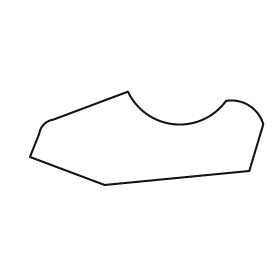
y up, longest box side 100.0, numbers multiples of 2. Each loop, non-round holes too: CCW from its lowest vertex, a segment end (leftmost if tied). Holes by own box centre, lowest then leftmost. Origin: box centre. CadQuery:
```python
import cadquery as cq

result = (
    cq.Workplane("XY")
    .moveTo(-18.0, -20.0)
    .lineTo(44.0, -14.0)
    .lineTo(50.0, 6.0)
    .threePointArc((44.0, 14.0), (34.0, 16.0))
    .threePointArc((12.0, 6.0), (-8.0, 20.0))
    .lineTo(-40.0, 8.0)
    .threePointArc((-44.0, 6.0), (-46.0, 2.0))
    .lineTo(-50.0, -8.0)
    .close()
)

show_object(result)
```